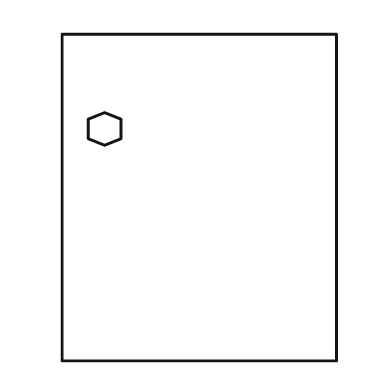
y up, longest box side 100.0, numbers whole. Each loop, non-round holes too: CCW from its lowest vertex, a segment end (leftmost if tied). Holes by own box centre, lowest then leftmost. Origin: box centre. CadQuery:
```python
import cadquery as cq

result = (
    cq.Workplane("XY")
    .moveTo(-42.0, -50.0)
    .lineTo(42.0, -50.0)
    .lineTo(42.0, 50.0)
    .lineTo(-42.0, 50.0)
    .close()
    .moveTo(-29.0, 16.0)
    .lineTo(-24.0, 18.0)
    .lineTo(-24.0, 24.0)
    .lineTo(-29.0, 26.0)
    .lineTo(-34.0, 24.0)
    .lineTo(-34.0, 18.0)
    .close()
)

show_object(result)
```